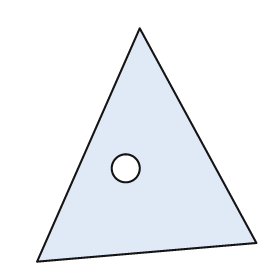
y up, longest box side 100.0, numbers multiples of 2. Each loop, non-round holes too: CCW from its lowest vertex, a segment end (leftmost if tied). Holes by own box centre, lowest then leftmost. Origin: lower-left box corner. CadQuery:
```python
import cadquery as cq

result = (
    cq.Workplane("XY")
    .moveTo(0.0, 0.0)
    .lineTo(94.0, 8.0)
    .lineTo(44.0, 100.0)
    .close()
    .moveTo(38.0, 40.0)
    .circle(6.0)
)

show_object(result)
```